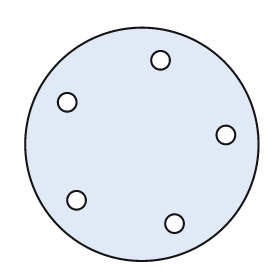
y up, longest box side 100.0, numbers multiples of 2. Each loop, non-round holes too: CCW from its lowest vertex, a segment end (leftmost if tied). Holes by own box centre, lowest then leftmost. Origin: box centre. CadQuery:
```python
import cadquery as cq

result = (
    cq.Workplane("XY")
    .moveTo(0.0, 0.0)
    .circle(50.0)
    .moveTo(14.0, -34.0)
    .circle(4.0)
    .moveTo(-28.0, -24.0)
    .circle(4.0)
    .moveTo(36.0, 4.0)
    .circle(4.0)
    .moveTo(-32.0, 18.0)
    .circle(4.0)
    .moveTo(8.0, 36.0)
    .circle(4.0)
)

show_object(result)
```